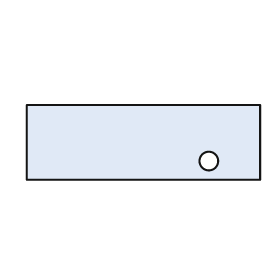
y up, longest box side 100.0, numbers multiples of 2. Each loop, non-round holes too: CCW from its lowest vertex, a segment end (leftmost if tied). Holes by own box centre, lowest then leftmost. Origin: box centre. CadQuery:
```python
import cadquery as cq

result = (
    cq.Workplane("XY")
    .moveTo(-50.0, -16.0)
    .lineTo(50.0, -16.0)
    .lineTo(50.0, 16.0)
    .lineTo(-50.0, 16.0)
    .close()
    .moveTo(28.0, -8.0)
    .circle(4.0)
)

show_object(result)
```